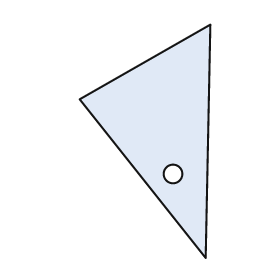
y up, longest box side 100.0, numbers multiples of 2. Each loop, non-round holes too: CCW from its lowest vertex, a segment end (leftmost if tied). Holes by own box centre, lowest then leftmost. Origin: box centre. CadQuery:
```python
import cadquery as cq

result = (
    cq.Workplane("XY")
    .moveTo(26.0, -50.0)
    .lineTo(28.0, 50.0)
    .lineTo(-28.0, 18.0)
    .close()
    .moveTo(12.0, -14.0)
    .circle(4.0)
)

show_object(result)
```